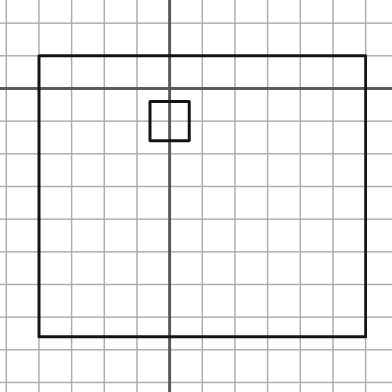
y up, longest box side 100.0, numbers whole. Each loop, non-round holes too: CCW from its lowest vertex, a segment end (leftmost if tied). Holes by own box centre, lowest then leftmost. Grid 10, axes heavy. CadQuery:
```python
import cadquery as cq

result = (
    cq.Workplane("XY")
    .moveTo(-40.0, -76.0)
    .lineTo(60.0, -76.0)
    .lineTo(60.0, 10.0)
    .lineTo(-40.0, 10.0)
    .close()
    .moveTo(-6.0, -16.0)
    .lineTo(6.0, -16.0)
    .lineTo(6.0, -4.0)
    .lineTo(-6.0, -4.0)
    .close()
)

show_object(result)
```